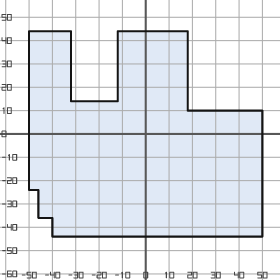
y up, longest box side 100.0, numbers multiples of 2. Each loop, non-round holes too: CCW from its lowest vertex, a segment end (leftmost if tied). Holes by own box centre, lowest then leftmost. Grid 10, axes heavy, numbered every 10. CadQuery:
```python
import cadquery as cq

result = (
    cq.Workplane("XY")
    .moveTo(-40.0, -44.0)
    .lineTo(50.0, -44.0)
    .lineTo(50.0, 10.0)
    .lineTo(18.0, 10.0)
    .lineTo(18.0, 44.0)
    .lineTo(-12.0, 44.0)
    .lineTo(-12.0, 14.0)
    .lineTo(-32.0, 14.0)
    .lineTo(-32.0, 44.0)
    .lineTo(-50.0, 44.0)
    .lineTo(-50.0, -24.0)
    .lineTo(-46.0, -24.0)
    .lineTo(-46.0, -36.0)
    .lineTo(-40.0, -36.0)
    .close()
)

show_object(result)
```